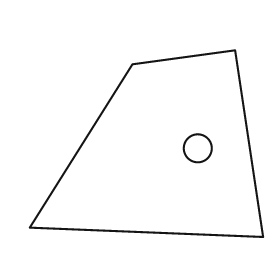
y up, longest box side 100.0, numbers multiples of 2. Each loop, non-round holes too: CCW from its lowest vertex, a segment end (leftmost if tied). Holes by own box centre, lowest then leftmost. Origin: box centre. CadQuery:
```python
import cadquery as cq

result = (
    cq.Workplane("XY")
    .moveTo(50.0, -40.0)
    .lineTo(38.0, 40.0)
    .lineTo(-6.0, 34.0)
    .lineTo(-50.0, -36.0)
    .close()
    .moveTo(22.0, -2.0)
    .circle(6.0)
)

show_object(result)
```